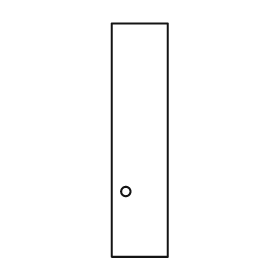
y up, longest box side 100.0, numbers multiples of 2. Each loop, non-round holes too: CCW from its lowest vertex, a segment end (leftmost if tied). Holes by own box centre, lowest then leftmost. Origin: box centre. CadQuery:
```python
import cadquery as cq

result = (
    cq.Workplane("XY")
    .moveTo(-12.0, -50.0)
    .lineTo(12.0, -50.0)
    .lineTo(12.0, 50.0)
    .lineTo(-12.0, 50.0)
    .close()
    .moveTo(-6.0, -22.0)
    .circle(2.0)
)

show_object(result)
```